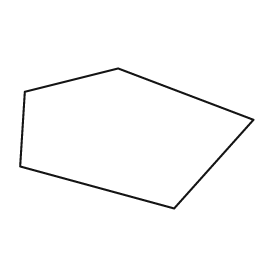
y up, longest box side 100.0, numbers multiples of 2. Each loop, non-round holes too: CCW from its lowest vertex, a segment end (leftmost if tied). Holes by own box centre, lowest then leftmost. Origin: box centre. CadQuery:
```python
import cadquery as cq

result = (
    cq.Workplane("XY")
    .moveTo(16.0, -30.0)
    .lineTo(50.0, 8.0)
    .lineTo(-8.0, 30.0)
    .lineTo(-48.0, 20.0)
    .lineTo(-50.0, -12.0)
    .close()
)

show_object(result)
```